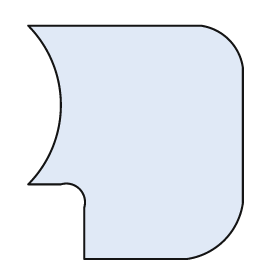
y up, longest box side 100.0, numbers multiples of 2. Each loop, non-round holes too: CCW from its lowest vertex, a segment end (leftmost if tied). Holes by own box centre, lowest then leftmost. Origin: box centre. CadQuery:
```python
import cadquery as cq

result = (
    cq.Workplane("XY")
    .moveTo(-22.0, -50.0)
    .lineTo(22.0, -50.0)
    .threePointArc((38.0, -42.0), (46.0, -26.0))
    .lineTo(46.0, 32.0)
    .threePointArc((40.0, 44.0), (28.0, 50.0))
    .lineTo(-46.0, 50.0)
    .threePointArc((-32.0, 16.0), (-46.0, -18.0))
    .lineTo(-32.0, -18.0)
    .threePointArc((-24.0, -20.0), (-22.0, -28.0))
    .close()
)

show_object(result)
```